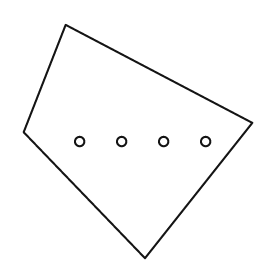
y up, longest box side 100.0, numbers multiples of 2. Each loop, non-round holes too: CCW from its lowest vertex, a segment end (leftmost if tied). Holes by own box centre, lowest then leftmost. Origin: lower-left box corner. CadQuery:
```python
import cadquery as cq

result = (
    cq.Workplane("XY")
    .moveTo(52.0, 0.0)
    .lineTo(98.0, 58.0)
    .lineTo(18.0, 100.0)
    .lineTo(0.0, 54.0)
    .close()
    .moveTo(24.0, 50.0)
    .circle(2.0)
    .moveTo(42.0, 50.0)
    .circle(2.0)
    .moveTo(60.0, 50.0)
    .circle(2.0)
    .moveTo(78.0, 50.0)
    .circle(2.0)
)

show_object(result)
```